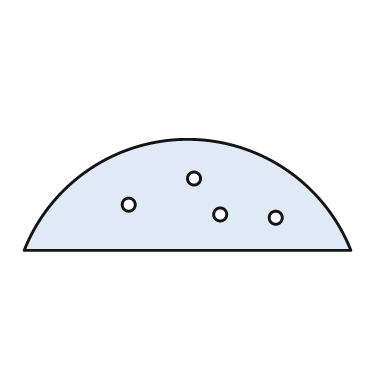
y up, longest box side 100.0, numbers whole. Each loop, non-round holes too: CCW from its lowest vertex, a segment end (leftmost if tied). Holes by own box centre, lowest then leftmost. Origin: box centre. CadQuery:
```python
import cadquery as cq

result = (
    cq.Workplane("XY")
    .moveTo(-50.0, -17.0)
    .lineTo(50.0, -17.0)
    .threePointArc((0.0, 17.0), (-50.0, -17.0))
    .close()
    .moveTo(27.0, -7.0)
    .circle(2.0)
    .moveTo(10.0, -6.0)
    .circle(2.0)
    .moveTo(-18.0, -3.0)
    .circle(2.0)
    .moveTo(2.0, 5.0)
    .circle(2.0)
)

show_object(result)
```